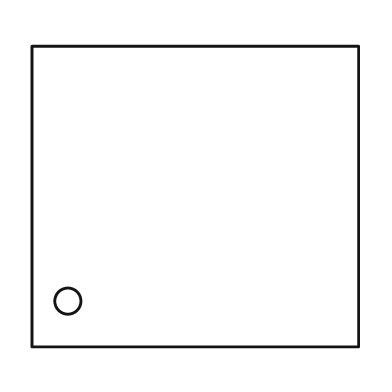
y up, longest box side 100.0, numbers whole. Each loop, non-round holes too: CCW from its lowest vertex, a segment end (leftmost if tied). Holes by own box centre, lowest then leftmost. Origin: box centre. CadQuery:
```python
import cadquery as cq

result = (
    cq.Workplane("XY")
    .moveTo(-50.0, -46.0)
    .lineTo(50.0, -46.0)
    .lineTo(50.0, 46.0)
    .lineTo(-50.0, 46.0)
    .close()
    .moveTo(-39.0, -32.0)
    .circle(4.0)
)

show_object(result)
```